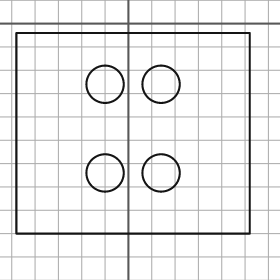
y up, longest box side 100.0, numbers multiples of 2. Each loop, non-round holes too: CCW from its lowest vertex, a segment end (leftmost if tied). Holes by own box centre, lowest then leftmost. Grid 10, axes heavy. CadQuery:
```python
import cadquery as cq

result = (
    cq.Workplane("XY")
    .moveTo(-48.0, -90.0)
    .lineTo(52.0, -90.0)
    .lineTo(52.0, -4.0)
    .lineTo(-48.0, -4.0)
    .close()
    .moveTo(-10.0, -64.0)
    .circle(8.0)
    .moveTo(14.0, -64.0)
    .circle(8.0)
    .moveTo(-10.0, -26.0)
    .circle(8.0)
    .moveTo(14.0, -26.0)
    .circle(8.0)
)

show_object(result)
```